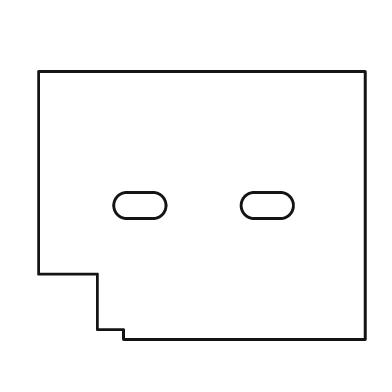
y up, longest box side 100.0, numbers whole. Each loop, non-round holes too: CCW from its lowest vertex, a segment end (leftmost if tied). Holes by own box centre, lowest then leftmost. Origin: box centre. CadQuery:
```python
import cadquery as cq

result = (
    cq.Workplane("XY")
    .moveTo(-24.0, -41.0)
    .lineTo(50.0, -41.0)
    .lineTo(50.0, 41.0)
    .lineTo(-50.0, 41.0)
    .lineTo(-50.0, -21.0)
    .lineTo(-32.0, -21.0)
    .lineTo(-32.0, -38.0)
    .lineTo(-24.0, -38.0)
    .close()
    .moveTo(-23.0, -4.0)
    .lineTo(-15.0, -4.0)
    .threePointArc((-11.0, 0.0), (-15.0, 4.0))
    .lineTo(-23.0, 4.0)
    .threePointArc((-27.0, 0.0), (-23.0, -4.0))
    .close()
    .moveTo(16.0, -4.0)
    .lineTo(24.0, -4.0)
    .threePointArc((28.0, 0.0), (24.0, 4.0))
    .lineTo(16.0, 4.0)
    .threePointArc((12.0, 0.0), (16.0, -4.0))
    .close()
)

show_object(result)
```